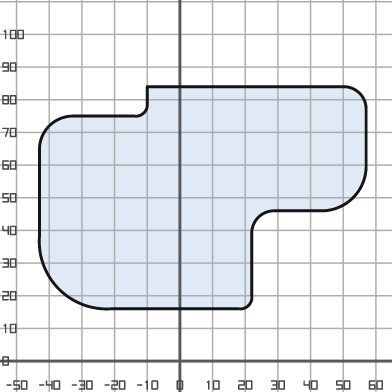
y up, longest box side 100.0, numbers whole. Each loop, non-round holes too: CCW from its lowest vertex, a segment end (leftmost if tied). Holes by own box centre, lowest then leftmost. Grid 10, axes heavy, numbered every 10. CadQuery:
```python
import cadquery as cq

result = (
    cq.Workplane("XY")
    .moveTo(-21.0, 16.0)
    .lineTo(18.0, 16.0)
    .threePointArc((21.0, 17.0), (22.0, 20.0))
    .lineTo(22.0, 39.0)
    .threePointArc((24.0, 44.0), (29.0, 46.0))
    .lineTo(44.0, 46.0)
    .threePointArc((53.0, 50.0), (57.0, 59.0))
    .lineTo(57.0, 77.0)
    .threePointArc((55.0, 82.0), (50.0, 84.0))
    .lineTo(-10.0, 84.0)
    .lineTo(-10.0, 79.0)
    .threePointArc((-11.0, 76.0), (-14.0, 75.0))
    .lineTo(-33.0, 75.0)
    .threePointArc((-40.0, 72.0), (-43.0, 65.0))
    .lineTo(-43.0, 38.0)
    .threePointArc((-37.0, 22.0), (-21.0, 16.0))
    .close()
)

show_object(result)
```